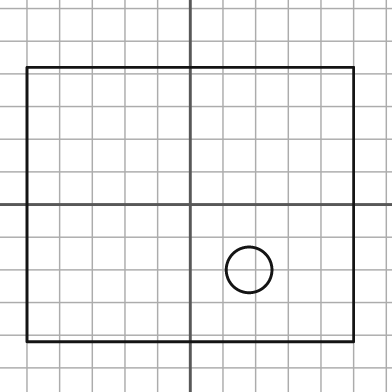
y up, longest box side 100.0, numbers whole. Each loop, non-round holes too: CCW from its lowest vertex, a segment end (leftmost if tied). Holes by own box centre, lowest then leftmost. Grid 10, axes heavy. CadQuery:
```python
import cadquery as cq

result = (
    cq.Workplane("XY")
    .moveTo(-50.0, -42.0)
    .lineTo(50.0, -42.0)
    .lineTo(50.0, 42.0)
    .lineTo(-50.0, 42.0)
    .close()
    .moveTo(18.0, -20.0)
    .circle(7.0)
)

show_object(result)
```